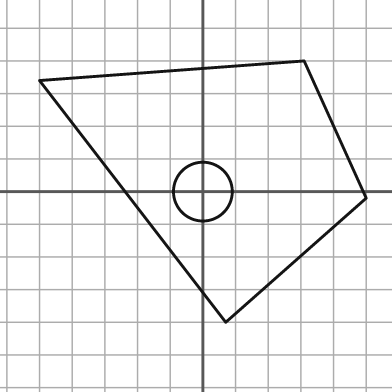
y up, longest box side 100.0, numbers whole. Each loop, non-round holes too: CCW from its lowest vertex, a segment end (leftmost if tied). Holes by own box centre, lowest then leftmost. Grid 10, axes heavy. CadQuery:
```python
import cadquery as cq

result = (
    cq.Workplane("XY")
    .moveTo(7.0, -40.0)
    .lineTo(50.0, -2.0)
    .lineTo(31.0, 40.0)
    .lineTo(-50.0, 34.0)
    .close()
    .moveTo(0.0, 0.0)
    .circle(9.0)
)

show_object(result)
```